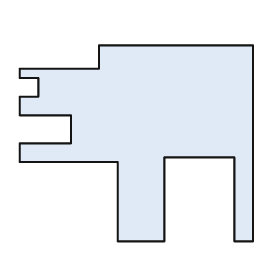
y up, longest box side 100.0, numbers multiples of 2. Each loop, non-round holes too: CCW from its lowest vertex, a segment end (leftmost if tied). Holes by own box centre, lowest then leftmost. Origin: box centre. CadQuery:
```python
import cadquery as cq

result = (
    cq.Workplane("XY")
    .moveTo(-8.0, -42.0)
    .lineTo(12.0, -42.0)
    .lineTo(12.0, -6.0)
    .lineTo(42.0, -6.0)
    .lineTo(42.0, -42.0)
    .lineTo(50.0, -42.0)
    .lineTo(50.0, 42.0)
    .lineTo(-16.0, 42.0)
    .lineTo(-16.0, 32.0)
    .lineTo(-50.0, 32.0)
    .lineTo(-50.0, 28.0)
    .lineTo(-42.0, 28.0)
    .lineTo(-42.0, 20.0)
    .lineTo(-50.0, 20.0)
    .lineTo(-50.0, 12.0)
    .lineTo(-28.0, 12.0)
    .lineTo(-28.0, 0.0)
    .lineTo(-50.0, 0.0)
    .lineTo(-50.0, -8.0)
    .lineTo(-8.0, -8.0)
    .close()
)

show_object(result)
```